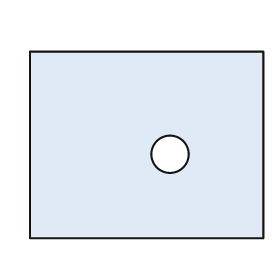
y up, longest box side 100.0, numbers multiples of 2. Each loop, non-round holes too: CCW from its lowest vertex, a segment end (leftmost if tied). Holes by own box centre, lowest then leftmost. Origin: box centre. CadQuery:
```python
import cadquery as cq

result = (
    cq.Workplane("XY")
    .moveTo(-50.0, -40.0)
    .lineTo(50.0, -40.0)
    .lineTo(50.0, 40.0)
    .lineTo(-50.0, 40.0)
    .close()
    .moveTo(10.0, -4.0)
    .circle(8.0)
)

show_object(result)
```